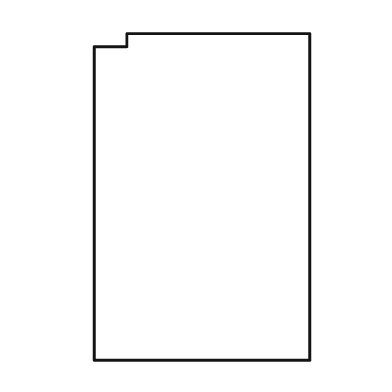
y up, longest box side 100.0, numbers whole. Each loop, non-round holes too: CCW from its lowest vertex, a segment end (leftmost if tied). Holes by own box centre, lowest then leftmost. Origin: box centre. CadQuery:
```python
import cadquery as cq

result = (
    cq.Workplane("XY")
    .moveTo(-33.0, -50.0)
    .lineTo(33.0, -50.0)
    .lineTo(33.0, 50.0)
    .lineTo(-23.0, 50.0)
    .lineTo(-23.0, 46.0)
    .lineTo(-33.0, 46.0)
    .close()
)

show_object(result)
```